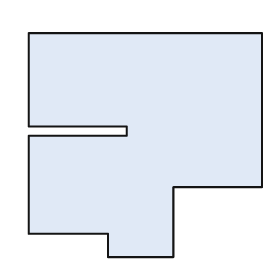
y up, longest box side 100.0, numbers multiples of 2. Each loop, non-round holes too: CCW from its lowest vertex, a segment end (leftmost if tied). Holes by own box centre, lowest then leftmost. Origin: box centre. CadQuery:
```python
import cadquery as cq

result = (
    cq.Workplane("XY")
    .moveTo(-16.0, -48.0)
    .lineTo(12.0, -48.0)
    .lineTo(12.0, -18.0)
    .lineTo(50.0, -18.0)
    .lineTo(50.0, 48.0)
    .lineTo(-50.0, 48.0)
    .lineTo(-50.0, 8.0)
    .lineTo(-8.0, 8.0)
    .lineTo(-8.0, 4.0)
    .lineTo(-50.0, 4.0)
    .lineTo(-50.0, -38.0)
    .lineTo(-16.0, -38.0)
    .close()
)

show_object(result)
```